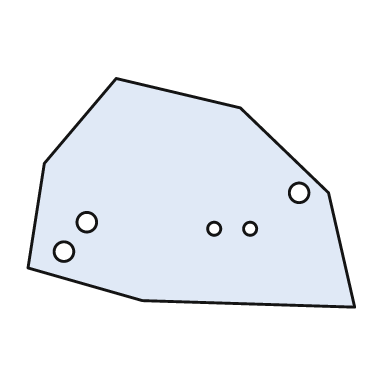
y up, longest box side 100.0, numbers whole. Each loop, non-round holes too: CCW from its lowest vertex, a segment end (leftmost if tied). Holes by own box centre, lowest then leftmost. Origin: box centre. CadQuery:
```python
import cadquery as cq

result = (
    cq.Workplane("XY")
    .moveTo(50.0, -35.0)
    .lineTo(42.0, 0.0)
    .lineTo(15.0, 26.0)
    .lineTo(-23.0, 35.0)
    .lineTo(-45.0, 9.0)
    .lineTo(-50.0, -23.0)
    .lineTo(-15.0, -33.0)
    .close()
    .moveTo(-39.0, -18.0)
    .circle(3.0)
    .moveTo(7.0, -11.0)
    .circle(2.0)
    .moveTo(18.0, -11.0)
    .circle(2.0)
    .moveTo(-32.0, -9.0)
    .circle(3.0)
    .moveTo(33.0, 0.0)
    .circle(3.0)
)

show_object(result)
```